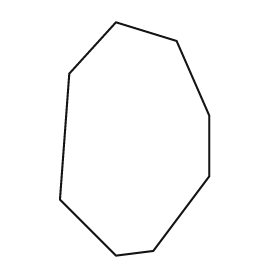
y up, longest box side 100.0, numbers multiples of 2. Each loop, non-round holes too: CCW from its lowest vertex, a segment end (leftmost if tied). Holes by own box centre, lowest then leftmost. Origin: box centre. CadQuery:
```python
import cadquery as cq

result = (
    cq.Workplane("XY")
    .moveTo(-8.0, -50.0)
    .lineTo(8.0, -48.0)
    .lineTo(32.0, -16.0)
    .lineTo(32.0, 10.0)
    .lineTo(18.0, 42.0)
    .lineTo(-8.0, 50.0)
    .lineTo(-28.0, 28.0)
    .lineTo(-32.0, -26.0)
    .close()
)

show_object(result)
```